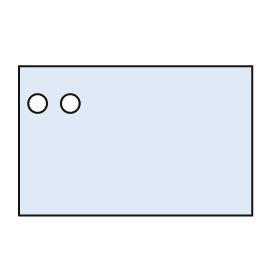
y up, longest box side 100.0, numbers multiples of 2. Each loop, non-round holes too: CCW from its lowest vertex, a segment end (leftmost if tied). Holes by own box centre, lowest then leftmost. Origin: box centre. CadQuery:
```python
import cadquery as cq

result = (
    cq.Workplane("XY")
    .moveTo(-50.0, -32.0)
    .lineTo(50.0, -32.0)
    .lineTo(50.0, 32.0)
    .lineTo(-50.0, 32.0)
    .close()
    .moveTo(-42.0, 16.0)
    .circle(4.0)
    .moveTo(-28.0, 16.0)
    .circle(4.0)
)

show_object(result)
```